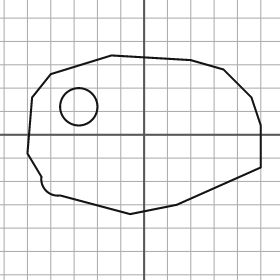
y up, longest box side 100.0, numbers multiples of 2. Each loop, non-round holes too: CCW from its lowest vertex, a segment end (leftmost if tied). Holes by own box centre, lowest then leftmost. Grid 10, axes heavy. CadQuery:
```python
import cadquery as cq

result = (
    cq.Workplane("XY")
    .moveTo(-6.0, -34.0)
    .lineTo(14.0, -30.0)
    .lineTo(50.0, -14.0)
    .lineTo(50.0, 4.0)
    .lineTo(46.0, 16.0)
    .lineTo(34.0, 28.0)
    .lineTo(20.0, 32.0)
    .lineTo(-14.0, 34.0)
    .lineTo(-40.0, 26.0)
    .lineTo(-48.0, 16.0)
    .lineTo(-50.0, -8.0)
    .lineTo(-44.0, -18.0)
    .threePointArc((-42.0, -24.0), (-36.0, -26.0))
    .close()
    .moveTo(-28.0, 12.0)
    .circle(8.0)
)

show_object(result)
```